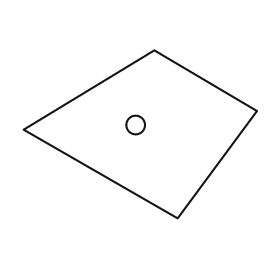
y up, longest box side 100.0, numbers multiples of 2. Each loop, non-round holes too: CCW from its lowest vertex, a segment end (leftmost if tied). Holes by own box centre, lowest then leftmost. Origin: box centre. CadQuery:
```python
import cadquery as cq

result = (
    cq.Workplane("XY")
    .moveTo(16.0, -36.0)
    .lineTo(50.0, 10.0)
    .lineTo(6.0, 36.0)
    .lineTo(-50.0, 2.0)
    .close()
    .moveTo(-2.0, 4.0)
    .circle(4.0)
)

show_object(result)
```